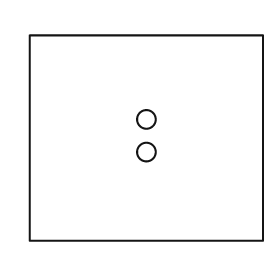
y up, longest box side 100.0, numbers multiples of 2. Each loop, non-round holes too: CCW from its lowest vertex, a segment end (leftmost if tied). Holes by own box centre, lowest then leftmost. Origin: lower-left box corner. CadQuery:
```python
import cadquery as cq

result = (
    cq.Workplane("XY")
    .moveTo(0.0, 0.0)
    .lineTo(100.0, 0.0)
    .lineTo(100.0, 88.0)
    .lineTo(0.0, 88.0)
    .close()
    .moveTo(50.0, 38.0)
    .circle(4.0)
    .moveTo(50.0, 52.0)
    .circle(4.0)
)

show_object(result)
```